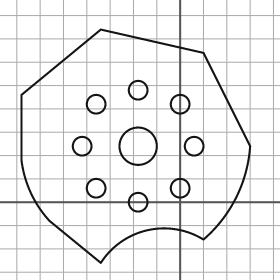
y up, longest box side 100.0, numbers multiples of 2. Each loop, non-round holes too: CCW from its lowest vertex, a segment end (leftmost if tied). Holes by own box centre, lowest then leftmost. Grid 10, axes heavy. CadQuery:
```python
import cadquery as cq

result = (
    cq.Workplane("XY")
    .moveTo(-34.0, -26.0)
    .threePointArc((-14.0, -12.0), (10.0, -16.0))
    .threePointArc((24.0, 2.0), (30.0, 24.0))
    .lineTo(10.0, 64.0)
    .lineTo(-34.0, 74.0)
    .lineTo(-68.0, 46.0)
    .lineTo(-68.0, 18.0)
    .threePointArc((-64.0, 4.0), (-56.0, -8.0))
    .close()
    .moveTo(-18.0, 0.0)
    .circle(4.0)
    .moveTo(-36.0, 6.0)
    .circle(4.0)
    .moveTo(0.0, 6.0)
    .circle(4.0)
    .moveTo(-42.0, 24.0)
    .circle(4.0)
    .moveTo(-18.0, 24.0)
    .circle(8.0)
    .moveTo(6.0, 24.0)
    .circle(4.0)
    .moveTo(-36.0, 42.0)
    .circle(4.0)
    .moveTo(0.0, 42.0)
    .circle(4.0)
    .moveTo(-18.0, 48.0)
    .circle(4.0)
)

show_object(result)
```